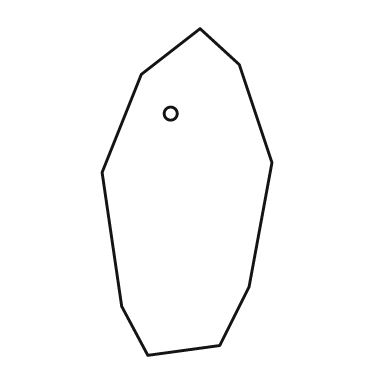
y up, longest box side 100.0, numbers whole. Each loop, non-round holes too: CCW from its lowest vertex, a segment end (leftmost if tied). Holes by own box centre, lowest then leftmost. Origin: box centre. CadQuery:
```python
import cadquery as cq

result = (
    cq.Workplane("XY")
    .moveTo(-12.0, -50.0)
    .lineTo(10.0, -47.0)
    .lineTo(19.0, -29.0)
    .lineTo(26.0, 9.0)
    .lineTo(16.0, 39.0)
    .lineTo(4.0, 50.0)
    .lineTo(-14.0, 36.0)
    .lineTo(-26.0, 6.0)
    .lineTo(-20.0, -35.0)
    .close()
    .moveTo(-5.0, 24.0)
    .circle(2.0)
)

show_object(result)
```